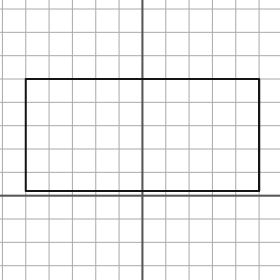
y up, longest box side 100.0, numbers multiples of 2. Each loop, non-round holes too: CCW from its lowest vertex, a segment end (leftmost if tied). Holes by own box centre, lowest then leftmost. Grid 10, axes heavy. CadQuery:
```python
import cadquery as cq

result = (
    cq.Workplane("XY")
    .moveTo(-50.0, 2.0)
    .lineTo(50.0, 2.0)
    .lineTo(50.0, 50.0)
    .lineTo(-50.0, 50.0)
    .close()
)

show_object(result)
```